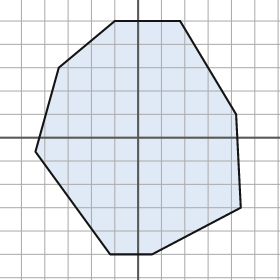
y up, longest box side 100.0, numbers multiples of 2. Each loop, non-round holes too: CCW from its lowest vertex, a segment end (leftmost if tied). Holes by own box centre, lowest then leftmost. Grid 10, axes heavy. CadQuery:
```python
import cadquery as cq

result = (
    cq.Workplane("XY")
    .moveTo(-12.0, -50.0)
    .lineTo(6.0, -50.0)
    .lineTo(44.0, -30.0)
    .lineTo(42.0, 10.0)
    .lineTo(18.0, 50.0)
    .lineTo(-10.0, 50.0)
    .lineTo(-34.0, 30.0)
    .lineTo(-44.0, -6.0)
    .close()
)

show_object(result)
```